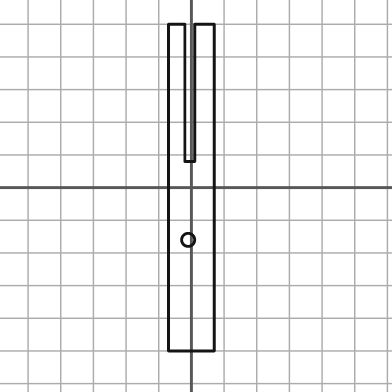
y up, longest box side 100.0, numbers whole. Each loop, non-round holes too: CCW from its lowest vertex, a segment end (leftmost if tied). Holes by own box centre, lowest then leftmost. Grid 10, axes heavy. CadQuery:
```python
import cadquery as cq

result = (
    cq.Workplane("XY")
    .moveTo(-7.0, -50.0)
    .lineTo(7.0, -50.0)
    .lineTo(7.0, 50.0)
    .lineTo(1.0, 50.0)
    .lineTo(1.0, 8.0)
    .lineTo(-2.0, 8.0)
    .lineTo(-2.0, 50.0)
    .lineTo(-7.0, 50.0)
    .close()
    .moveTo(-1.0, -16.0)
    .circle(2.0)
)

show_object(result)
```